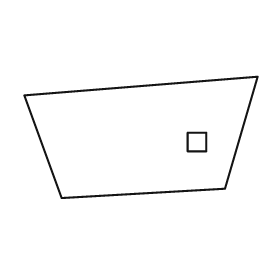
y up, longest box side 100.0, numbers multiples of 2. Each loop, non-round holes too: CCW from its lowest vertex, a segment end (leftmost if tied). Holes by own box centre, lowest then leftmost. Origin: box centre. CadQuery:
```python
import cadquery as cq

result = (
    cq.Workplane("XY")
    .moveTo(-34.0, -26.0)
    .lineTo(36.0, -22.0)
    .lineTo(50.0, 26.0)
    .lineTo(-50.0, 18.0)
    .close()
    .moveTo(20.0, -6.0)
    .lineTo(28.0, -6.0)
    .lineTo(28.0, 2.0)
    .lineTo(20.0, 2.0)
    .close()
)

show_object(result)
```